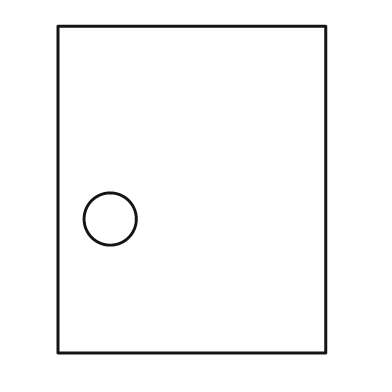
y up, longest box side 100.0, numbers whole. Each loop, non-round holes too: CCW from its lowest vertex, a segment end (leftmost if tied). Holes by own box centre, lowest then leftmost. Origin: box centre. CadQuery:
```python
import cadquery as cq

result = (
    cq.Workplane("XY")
    .moveTo(-41.0, -50.0)
    .lineTo(41.0, -50.0)
    .lineTo(41.0, 50.0)
    .lineTo(-41.0, 50.0)
    .close()
    .moveTo(-25.0, -9.0)
    .circle(8.0)
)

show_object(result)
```